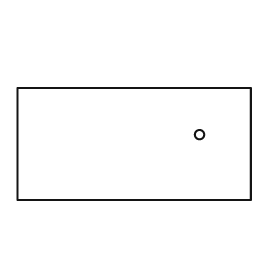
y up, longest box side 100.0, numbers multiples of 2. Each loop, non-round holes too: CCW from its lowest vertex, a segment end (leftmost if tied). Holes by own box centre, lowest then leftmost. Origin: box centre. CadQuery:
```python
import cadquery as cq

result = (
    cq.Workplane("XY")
    .moveTo(-50.0, -24.0)
    .lineTo(50.0, -24.0)
    .lineTo(50.0, 24.0)
    .lineTo(-50.0, 24.0)
    .close()
    .moveTo(28.0, 4.0)
    .circle(2.0)
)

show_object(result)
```